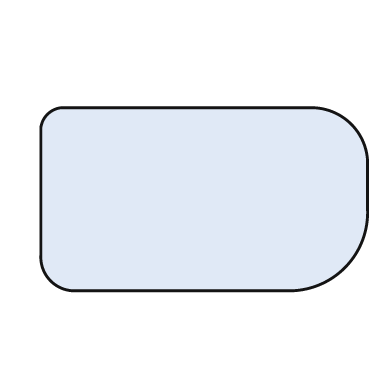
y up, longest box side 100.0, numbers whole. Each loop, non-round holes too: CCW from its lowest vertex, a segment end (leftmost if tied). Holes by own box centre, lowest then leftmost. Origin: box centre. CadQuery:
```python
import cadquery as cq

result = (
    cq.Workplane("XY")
    .moveTo(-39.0, -28.0)
    .lineTo(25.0, -28.0)
    .threePointArc((43.0, -21.0), (50.0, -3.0))
    .lineTo(50.0, 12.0)
    .threePointArc((45.0, 23.0), (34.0, 28.0))
    .lineTo(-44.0, 28.0)
    .threePointArc((-48.0, 26.0), (-50.0, 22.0))
    .lineTo(-50.0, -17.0)
    .threePointArc((-47.0, -25.0), (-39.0, -28.0))
    .close()
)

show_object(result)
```